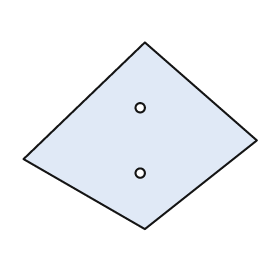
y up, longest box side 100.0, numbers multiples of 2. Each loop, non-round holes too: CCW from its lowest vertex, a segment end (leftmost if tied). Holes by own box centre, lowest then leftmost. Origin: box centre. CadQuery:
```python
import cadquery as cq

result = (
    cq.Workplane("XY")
    .moveTo(2.0, -40.0)
    .lineTo(50.0, -2.0)
    .lineTo(2.0, 40.0)
    .lineTo(-50.0, -10.0)
    .close()
    .moveTo(0.0, -16.0)
    .circle(2.0)
    .moveTo(0.0, 12.0)
    .circle(2.0)
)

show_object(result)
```